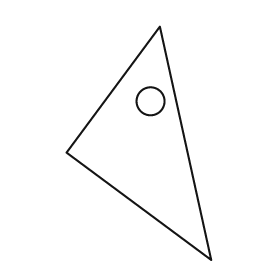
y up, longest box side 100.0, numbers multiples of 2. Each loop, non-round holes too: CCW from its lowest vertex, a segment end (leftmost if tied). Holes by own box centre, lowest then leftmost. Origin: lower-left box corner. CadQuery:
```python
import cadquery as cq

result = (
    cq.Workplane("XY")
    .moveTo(62.0, 0.0)
    .lineTo(40.0, 100.0)
    .lineTo(0.0, 46.0)
    .close()
    .moveTo(36.0, 68.0)
    .circle(6.0)
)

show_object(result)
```